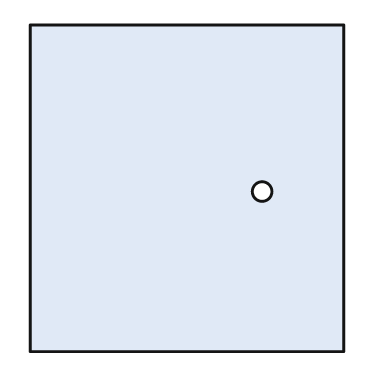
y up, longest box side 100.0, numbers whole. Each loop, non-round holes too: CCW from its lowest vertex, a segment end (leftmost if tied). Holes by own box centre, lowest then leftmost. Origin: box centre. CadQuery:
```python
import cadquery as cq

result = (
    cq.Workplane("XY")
    .moveTo(-48.0, -50.0)
    .lineTo(48.0, -50.0)
    .lineTo(48.0, 50.0)
    .lineTo(-48.0, 50.0)
    .close()
    .moveTo(23.0, -1.0)
    .circle(3.0)
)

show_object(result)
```